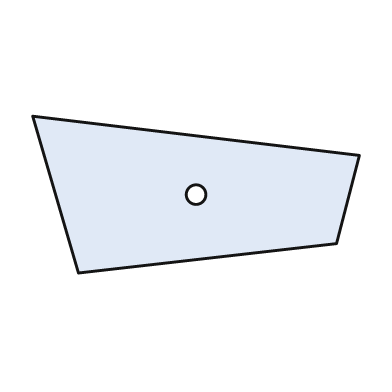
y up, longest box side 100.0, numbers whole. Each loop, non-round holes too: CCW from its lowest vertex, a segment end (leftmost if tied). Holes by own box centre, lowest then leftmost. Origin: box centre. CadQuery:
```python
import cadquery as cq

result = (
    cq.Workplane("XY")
    .moveTo(-36.0, -24.0)
    .lineTo(43.0, -15.0)
    .lineTo(50.0, 12.0)
    .lineTo(-50.0, 24.0)
    .close()
    .moveTo(0.0, 0.0)
    .circle(3.0)
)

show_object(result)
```